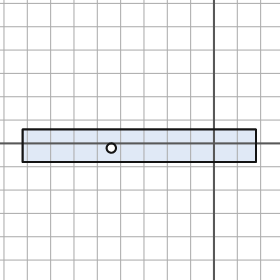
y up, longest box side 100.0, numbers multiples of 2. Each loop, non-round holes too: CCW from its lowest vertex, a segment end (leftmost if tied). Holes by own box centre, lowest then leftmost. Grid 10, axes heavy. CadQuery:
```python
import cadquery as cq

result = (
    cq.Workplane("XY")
    .moveTo(-82.0, -8.0)
    .lineTo(18.0, -8.0)
    .lineTo(18.0, 6.0)
    .lineTo(-82.0, 6.0)
    .close()
    .moveTo(-44.0, -2.0)
    .circle(2.0)
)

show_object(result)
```